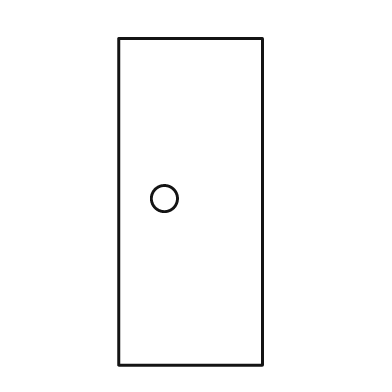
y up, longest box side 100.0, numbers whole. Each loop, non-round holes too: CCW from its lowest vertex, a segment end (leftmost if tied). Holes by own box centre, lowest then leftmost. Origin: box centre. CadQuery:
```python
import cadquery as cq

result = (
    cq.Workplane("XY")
    .moveTo(-22.0, -50.0)
    .lineTo(22.0, -50.0)
    .lineTo(22.0, 50.0)
    .lineTo(-22.0, 50.0)
    .close()
    .moveTo(-8.0, 1.0)
    .circle(4.0)
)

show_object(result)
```